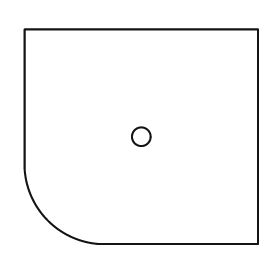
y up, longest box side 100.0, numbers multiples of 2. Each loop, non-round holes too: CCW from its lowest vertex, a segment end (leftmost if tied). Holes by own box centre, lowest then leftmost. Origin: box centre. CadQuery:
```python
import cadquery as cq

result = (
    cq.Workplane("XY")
    .moveTo(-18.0, -46.0)
    .lineTo(50.0, -46.0)
    .lineTo(50.0, 46.0)
    .lineTo(-50.0, 46.0)
    .lineTo(-50.0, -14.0)
    .threePointArc((-40.0, -36.0), (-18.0, -46.0))
    .close()
    .moveTo(0.0, 0.0)
    .circle(4.0)
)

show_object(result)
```